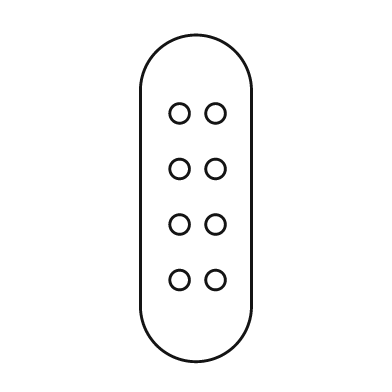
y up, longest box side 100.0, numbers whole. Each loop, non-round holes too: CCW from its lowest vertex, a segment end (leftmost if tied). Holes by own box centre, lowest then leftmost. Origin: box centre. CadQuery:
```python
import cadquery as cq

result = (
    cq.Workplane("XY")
    .moveTo(-17.0, -33.0)
    .threePointArc((0.0, -50.0), (17.0, -33.0))
    .lineTo(17.0, 33.0)
    .threePointArc((0.0, 50.0), (-17.0, 33.0))
    .close()
    .moveTo(-5.0, -25.0)
    .circle(3.0)
    .moveTo(6.0, -25.0)
    .circle(3.0)
    .moveTo(-5.0, -8.0)
    .circle(3.0)
    .moveTo(6.0, -8.0)
    .circle(3.0)
    .moveTo(-5.0, 9.0)
    .circle(3.0)
    .moveTo(6.0, 9.0)
    .circle(3.0)
    .moveTo(-5.0, 26.0)
    .circle(3.0)
    .moveTo(6.0, 26.0)
    .circle(3.0)
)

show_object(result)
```